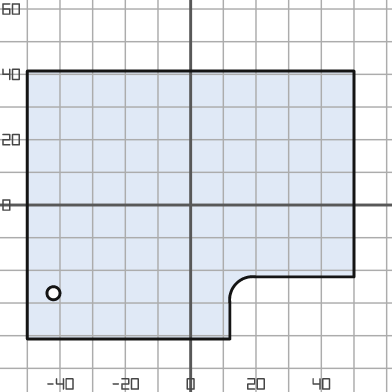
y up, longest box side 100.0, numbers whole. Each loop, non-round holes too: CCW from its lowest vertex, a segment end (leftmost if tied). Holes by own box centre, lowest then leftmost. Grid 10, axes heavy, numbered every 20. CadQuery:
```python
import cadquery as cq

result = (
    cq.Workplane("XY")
    .moveTo(-50.0, -41.0)
    .lineTo(12.0, -41.0)
    .lineTo(12.0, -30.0)
    .threePointArc((14.0, -24.0), (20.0, -22.0))
    .lineTo(50.0, -22.0)
    .lineTo(50.0, 41.0)
    .lineTo(-50.0, 41.0)
    .close()
    .moveTo(-42.0, -27.0)
    .circle(2.0)
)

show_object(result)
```